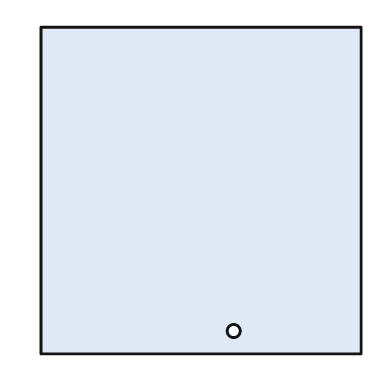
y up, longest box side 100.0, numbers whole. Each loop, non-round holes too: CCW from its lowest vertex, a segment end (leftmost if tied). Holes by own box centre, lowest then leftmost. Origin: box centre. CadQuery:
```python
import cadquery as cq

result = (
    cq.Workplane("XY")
    .moveTo(-49.0, -50.0)
    .lineTo(49.0, -50.0)
    .lineTo(49.0, 50.0)
    .lineTo(-49.0, 50.0)
    .close()
    .moveTo(10.0, -43.0)
    .circle(2.0)
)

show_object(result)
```